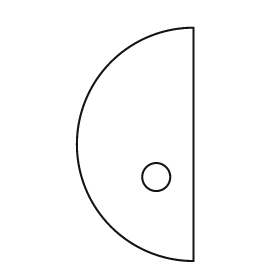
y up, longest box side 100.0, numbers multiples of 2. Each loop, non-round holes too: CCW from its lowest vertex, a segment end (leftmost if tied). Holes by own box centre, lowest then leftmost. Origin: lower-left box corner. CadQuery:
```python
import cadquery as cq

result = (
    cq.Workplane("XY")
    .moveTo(50.0, 0.0)
    .lineTo(50.0, 100.0)
    .threePointArc((0.0, 50.0), (50.0, 0.0))
    .close()
    .moveTo(34.0, 36.0)
    .circle(6.0)
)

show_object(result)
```